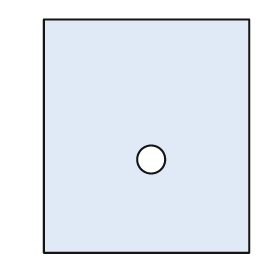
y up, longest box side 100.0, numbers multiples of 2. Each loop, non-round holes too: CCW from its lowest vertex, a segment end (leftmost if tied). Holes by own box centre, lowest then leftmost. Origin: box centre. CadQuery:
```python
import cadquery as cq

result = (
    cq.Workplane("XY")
    .moveTo(-44.0, -50.0)
    .lineTo(44.0, -50.0)
    .lineTo(44.0, 50.0)
    .lineTo(-44.0, 50.0)
    .close()
    .moveTo(2.0, -10.0)
    .circle(6.0)
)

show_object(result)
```